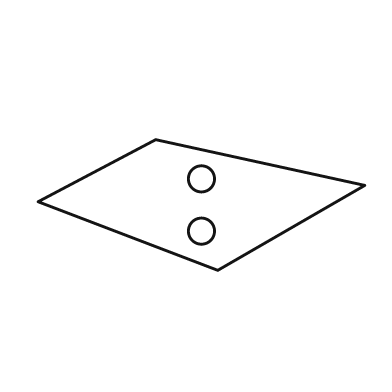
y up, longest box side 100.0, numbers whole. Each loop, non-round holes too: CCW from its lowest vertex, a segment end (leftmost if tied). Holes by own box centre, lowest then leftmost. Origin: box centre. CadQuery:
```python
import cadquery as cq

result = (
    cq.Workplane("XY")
    .moveTo(5.0, -20.0)
    .lineTo(50.0, 6.0)
    .lineTo(-14.0, 20.0)
    .lineTo(-50.0, 1.0)
    .close()
    .moveTo(0.0, -8.0)
    .circle(4.0)
    .moveTo(0.0, 8.0)
    .circle(4.0)
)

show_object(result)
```